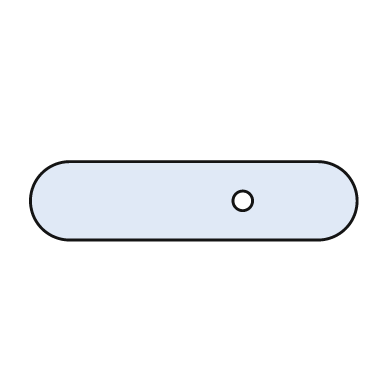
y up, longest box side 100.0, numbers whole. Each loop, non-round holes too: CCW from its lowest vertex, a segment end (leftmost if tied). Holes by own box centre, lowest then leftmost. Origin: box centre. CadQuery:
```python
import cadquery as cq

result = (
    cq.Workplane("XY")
    .moveTo(-38.0, -12.0)
    .lineTo(38.0, -12.0)
    .threePointArc((50.0, 0.0), (38.0, 12.0))
    .lineTo(-38.0, 12.0)
    .threePointArc((-50.0, 0.0), (-38.0, -12.0))
    .close()
    .moveTo(15.0, 0.0)
    .circle(3.0)
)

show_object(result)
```